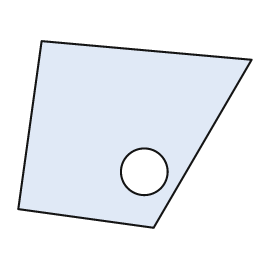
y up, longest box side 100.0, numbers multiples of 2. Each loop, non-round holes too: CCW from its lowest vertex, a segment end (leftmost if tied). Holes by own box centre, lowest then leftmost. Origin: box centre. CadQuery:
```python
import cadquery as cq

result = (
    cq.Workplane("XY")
    .moveTo(8.0, -40.0)
    .lineTo(50.0, 32.0)
    .lineTo(-40.0, 40.0)
    .lineTo(-50.0, -32.0)
    .close()
    .moveTo(4.0, -16.0)
    .circle(10.0)
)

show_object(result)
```